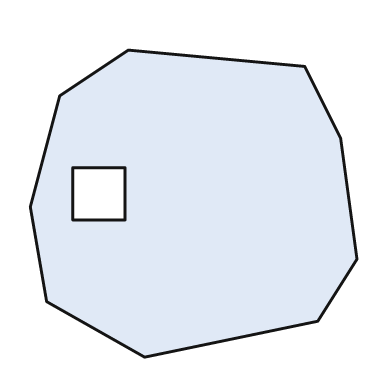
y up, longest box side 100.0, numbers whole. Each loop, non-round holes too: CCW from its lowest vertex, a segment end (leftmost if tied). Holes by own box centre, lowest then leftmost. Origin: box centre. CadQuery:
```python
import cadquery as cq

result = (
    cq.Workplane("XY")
    .moveTo(-15.0, -47.0)
    .lineTo(38.0, -36.0)
    .lineTo(50.0, -17.0)
    .lineTo(45.0, 20.0)
    .lineTo(34.0, 42.0)
    .lineTo(-20.0, 47.0)
    .lineTo(-41.0, 33.0)
    .lineTo(-50.0, -1.0)
    .lineTo(-45.0, -30.0)
    .close()
    .moveTo(-37.0, -5.0)
    .lineTo(-21.0, -5.0)
    .lineTo(-21.0, 11.0)
    .lineTo(-37.0, 11.0)
    .close()
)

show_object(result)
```